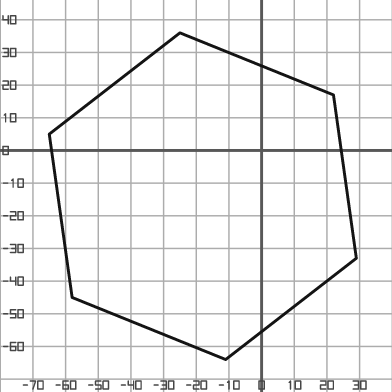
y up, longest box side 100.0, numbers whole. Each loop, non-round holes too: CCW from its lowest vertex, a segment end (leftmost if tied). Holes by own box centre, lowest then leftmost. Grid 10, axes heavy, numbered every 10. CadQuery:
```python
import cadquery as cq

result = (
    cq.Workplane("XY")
    .moveTo(-11.0, -64.0)
    .lineTo(29.0, -33.0)
    .lineTo(22.0, 17.0)
    .lineTo(-25.0, 36.0)
    .lineTo(-65.0, 5.0)
    .lineTo(-58.0, -45.0)
    .close()
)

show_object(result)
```